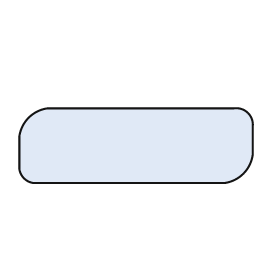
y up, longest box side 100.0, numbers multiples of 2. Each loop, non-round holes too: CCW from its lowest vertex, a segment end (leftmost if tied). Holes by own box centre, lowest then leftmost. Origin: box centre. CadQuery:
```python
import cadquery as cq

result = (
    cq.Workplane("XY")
    .moveTo(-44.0, -16.0)
    .lineTo(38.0, -16.0)
    .threePointArc((46.0, -12.0), (50.0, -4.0))
    .lineTo(50.0, 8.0)
    .threePointArc((48.0, 14.0), (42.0, 16.0))
    .lineTo(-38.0, 16.0)
    .threePointArc((-46.0, 12.0), (-50.0, 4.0))
    .lineTo(-50.0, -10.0)
    .threePointArc((-48.0, -14.0), (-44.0, -16.0))
    .close()
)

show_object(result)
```